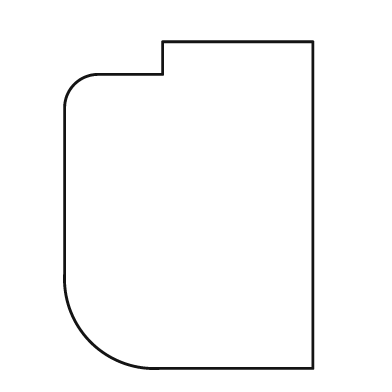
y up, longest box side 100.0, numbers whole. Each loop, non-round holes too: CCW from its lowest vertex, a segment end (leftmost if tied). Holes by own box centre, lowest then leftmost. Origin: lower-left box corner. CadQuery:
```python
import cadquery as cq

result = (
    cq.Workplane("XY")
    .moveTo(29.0, 0.0)
    .lineTo(76.0, 0.0)
    .lineTo(76.0, 100.0)
    .lineTo(30.0, 100.0)
    .lineTo(30.0, 90.0)
    .lineTo(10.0, 90.0)
    .threePointArc((3.0, 87.0), (0.0, 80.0))
    .lineTo(0.0, 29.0)
    .threePointArc((8.0, 8.0), (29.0, 0.0))
    .close()
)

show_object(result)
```